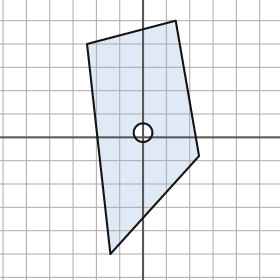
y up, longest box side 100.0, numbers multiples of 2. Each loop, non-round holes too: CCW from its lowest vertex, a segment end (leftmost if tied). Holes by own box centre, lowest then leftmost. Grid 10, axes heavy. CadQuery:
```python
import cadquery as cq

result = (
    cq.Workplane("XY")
    .moveTo(-14.0, -50.0)
    .lineTo(24.0, -8.0)
    .lineTo(14.0, 50.0)
    .lineTo(-24.0, 40.0)
    .close()
    .moveTo(0.0, 2.0)
    .circle(4.0)
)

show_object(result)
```